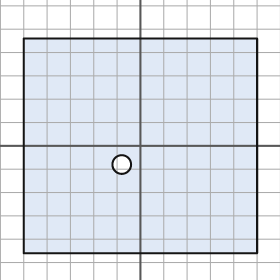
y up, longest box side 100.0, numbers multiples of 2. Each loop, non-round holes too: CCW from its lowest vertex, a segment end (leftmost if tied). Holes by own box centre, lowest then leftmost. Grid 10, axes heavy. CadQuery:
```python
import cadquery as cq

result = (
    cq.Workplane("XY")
    .moveTo(-50.0, -46.0)
    .lineTo(50.0, -46.0)
    .lineTo(50.0, 46.0)
    .lineTo(-50.0, 46.0)
    .close()
    .moveTo(-8.0, -8.0)
    .circle(4.0)
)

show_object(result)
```